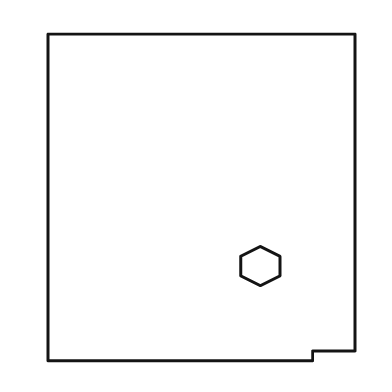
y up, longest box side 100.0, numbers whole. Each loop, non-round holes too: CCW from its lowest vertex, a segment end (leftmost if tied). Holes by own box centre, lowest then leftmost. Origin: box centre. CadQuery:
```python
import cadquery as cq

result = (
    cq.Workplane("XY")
    .moveTo(-47.0, -50.0)
    .lineTo(34.0, -50.0)
    .lineTo(34.0, -47.0)
    .lineTo(47.0, -47.0)
    .lineTo(47.0, 50.0)
    .lineTo(-47.0, 50.0)
    .close()
    .moveTo(18.0, -27.0)
    .lineTo(24.0, -24.0)
    .lineTo(24.0, -18.0)
    .lineTo(18.0, -15.0)
    .lineTo(12.0, -18.0)
    .lineTo(12.0, -24.0)
    .close()
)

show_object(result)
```